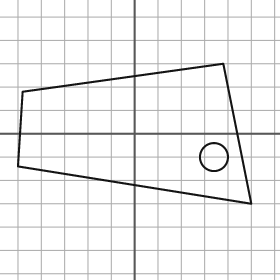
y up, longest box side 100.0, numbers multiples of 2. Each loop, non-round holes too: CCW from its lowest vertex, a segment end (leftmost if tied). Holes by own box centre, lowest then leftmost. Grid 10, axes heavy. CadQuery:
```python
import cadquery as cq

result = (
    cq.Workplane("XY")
    .moveTo(50.0, -30.0)
    .lineTo(38.0, 30.0)
    .lineTo(-48.0, 18.0)
    .lineTo(-50.0, -14.0)
    .close()
    .moveTo(34.0, -10.0)
    .circle(6.0)
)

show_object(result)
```